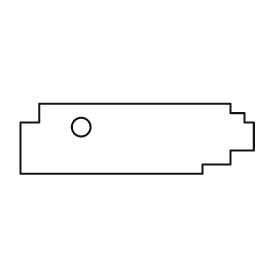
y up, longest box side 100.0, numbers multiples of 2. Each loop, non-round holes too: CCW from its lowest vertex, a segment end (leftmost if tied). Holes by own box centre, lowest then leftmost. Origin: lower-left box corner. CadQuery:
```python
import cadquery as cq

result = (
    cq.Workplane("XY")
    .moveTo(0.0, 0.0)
    .lineTo(78.0, 0.0)
    .lineTo(78.0, 4.0)
    .lineTo(90.0, 4.0)
    .lineTo(90.0, 10.0)
    .lineTo(100.0, 10.0)
    .lineTo(100.0, 22.0)
    .lineTo(96.0, 22.0)
    .lineTo(96.0, 26.0)
    .lineTo(90.0, 26.0)
    .lineTo(90.0, 30.0)
    .lineTo(8.0, 30.0)
    .lineTo(8.0, 22.0)
    .lineTo(0.0, 22.0)
    .close()
    .moveTo(26.0, 20.0)
    .circle(4.0)
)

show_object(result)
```